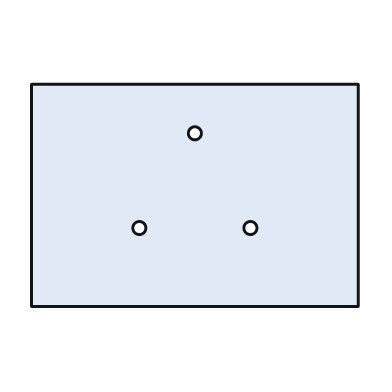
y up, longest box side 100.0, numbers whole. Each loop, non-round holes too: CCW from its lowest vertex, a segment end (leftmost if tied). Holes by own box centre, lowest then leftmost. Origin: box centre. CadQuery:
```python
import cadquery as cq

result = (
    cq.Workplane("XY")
    .moveTo(-50.0, -34.0)
    .lineTo(50.0, -34.0)
    .lineTo(50.0, 34.0)
    .lineTo(-50.0, 34.0)
    .close()
    .moveTo(-17.0, -10.0)
    .circle(2.0)
    .moveTo(17.0, -10.0)
    .circle(2.0)
    .moveTo(0.0, 19.0)
    .circle(2.0)
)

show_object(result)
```